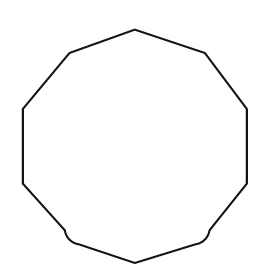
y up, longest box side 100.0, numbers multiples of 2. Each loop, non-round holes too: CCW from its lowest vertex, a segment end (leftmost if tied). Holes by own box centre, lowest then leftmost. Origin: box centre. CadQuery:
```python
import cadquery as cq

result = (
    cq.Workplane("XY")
    .moveTo(0.0, -50.0)
    .lineTo(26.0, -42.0)
    .threePointArc((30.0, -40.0), (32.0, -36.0))
    .lineTo(48.0, -16.0)
    .lineTo(48.0, 16.0)
    .lineTo(30.0, 40.0)
    .lineTo(0.0, 50.0)
    .lineTo(-28.0, 40.0)
    .lineTo(-48.0, 16.0)
    .lineTo(-48.0, -16.0)
    .lineTo(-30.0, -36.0)
    .threePointArc((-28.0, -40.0), (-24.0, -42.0))
    .close()
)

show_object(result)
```